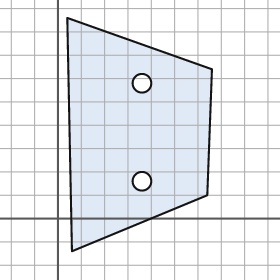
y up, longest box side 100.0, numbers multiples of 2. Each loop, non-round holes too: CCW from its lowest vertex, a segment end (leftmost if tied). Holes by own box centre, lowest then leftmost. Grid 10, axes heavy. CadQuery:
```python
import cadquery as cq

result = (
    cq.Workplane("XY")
    .moveTo(6.0, -14.0)
    .lineTo(64.0, 10.0)
    .lineTo(66.0, 64.0)
    .lineTo(4.0, 86.0)
    .close()
    .moveTo(36.0, 16.0)
    .circle(4.0)
    .moveTo(36.0, 58.0)
    .circle(4.0)
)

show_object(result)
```